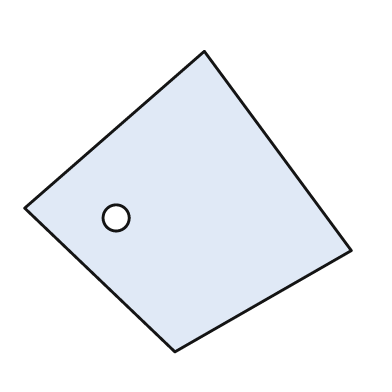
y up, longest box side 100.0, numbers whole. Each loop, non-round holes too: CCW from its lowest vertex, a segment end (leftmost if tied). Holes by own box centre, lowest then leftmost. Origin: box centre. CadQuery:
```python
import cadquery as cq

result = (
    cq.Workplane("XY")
    .moveTo(-4.0, -46.0)
    .lineTo(50.0, -15.0)
    .lineTo(5.0, 46.0)
    .lineTo(-50.0, -2.0)
    .close()
    .moveTo(-22.0, -5.0)
    .circle(4.0)
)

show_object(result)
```